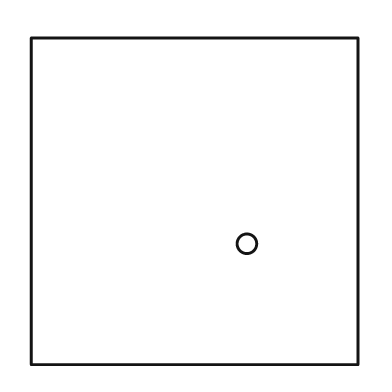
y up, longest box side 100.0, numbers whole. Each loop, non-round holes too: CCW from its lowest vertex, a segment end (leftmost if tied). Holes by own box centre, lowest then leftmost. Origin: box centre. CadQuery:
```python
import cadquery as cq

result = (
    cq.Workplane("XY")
    .moveTo(-50.0, -50.0)
    .lineTo(50.0, -50.0)
    .lineTo(50.0, 50.0)
    .lineTo(-50.0, 50.0)
    .close()
    .moveTo(16.0, -13.0)
    .circle(3.0)
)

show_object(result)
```